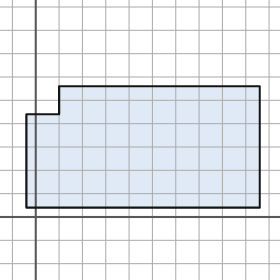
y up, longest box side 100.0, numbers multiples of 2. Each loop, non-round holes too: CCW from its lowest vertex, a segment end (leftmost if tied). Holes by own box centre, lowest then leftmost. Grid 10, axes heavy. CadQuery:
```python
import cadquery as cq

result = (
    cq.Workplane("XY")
    .moveTo(-4.0, 4.0)
    .lineTo(96.0, 4.0)
    .lineTo(96.0, 56.0)
    .lineTo(10.0, 56.0)
    .lineTo(10.0, 44.0)
    .lineTo(-4.0, 44.0)
    .close()
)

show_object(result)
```